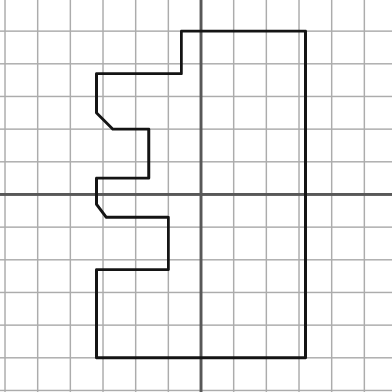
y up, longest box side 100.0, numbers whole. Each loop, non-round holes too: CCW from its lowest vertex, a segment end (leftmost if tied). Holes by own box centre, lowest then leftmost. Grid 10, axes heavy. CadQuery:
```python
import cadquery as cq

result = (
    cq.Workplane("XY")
    .moveTo(-32.0, -50.0)
    .lineTo(32.0, -50.0)
    .lineTo(32.0, 50.0)
    .lineTo(-6.0, 50.0)
    .lineTo(-6.0, 37.0)
    .lineTo(-32.0, 37.0)
    .lineTo(-32.0, 25.0)
    .lineTo(-27.0, 20.0)
    .lineTo(-16.0, 20.0)
    .lineTo(-16.0, 5.0)
    .lineTo(-32.0, 5.0)
    .lineTo(-32.0, -3.0)
    .lineTo(-29.0, -7.0)
    .lineTo(-10.0, -7.0)
    .lineTo(-10.0, -23.0)
    .lineTo(-32.0, -23.0)
    .close()
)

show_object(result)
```